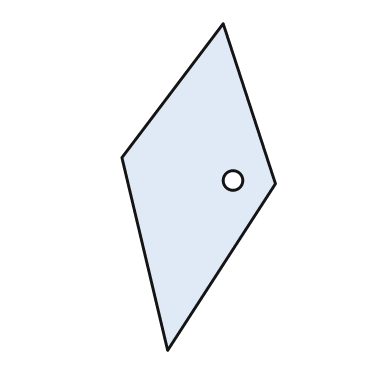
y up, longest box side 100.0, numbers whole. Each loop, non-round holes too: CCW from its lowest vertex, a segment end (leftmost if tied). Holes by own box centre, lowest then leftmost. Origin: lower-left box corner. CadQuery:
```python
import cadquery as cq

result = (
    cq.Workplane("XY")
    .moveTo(14.0, 0.0)
    .lineTo(47.0, 51.0)
    .lineTo(31.0, 100.0)
    .lineTo(0.0, 59.0)
    .close()
    .moveTo(34.0, 52.0)
    .circle(3.0)
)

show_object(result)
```